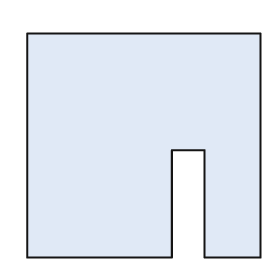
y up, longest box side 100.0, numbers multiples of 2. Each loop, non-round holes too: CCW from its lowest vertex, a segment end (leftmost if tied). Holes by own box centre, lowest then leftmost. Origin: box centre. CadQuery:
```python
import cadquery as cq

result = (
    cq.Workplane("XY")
    .moveTo(-50.0, -48.0)
    .lineTo(12.0, -48.0)
    .lineTo(12.0, -2.0)
    .lineTo(26.0, -2.0)
    .lineTo(26.0, -48.0)
    .lineTo(50.0, -48.0)
    .lineTo(50.0, 48.0)
    .lineTo(-50.0, 48.0)
    .close()
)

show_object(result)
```